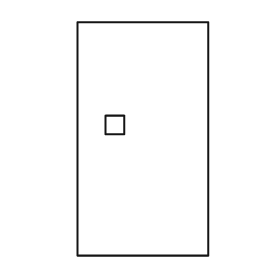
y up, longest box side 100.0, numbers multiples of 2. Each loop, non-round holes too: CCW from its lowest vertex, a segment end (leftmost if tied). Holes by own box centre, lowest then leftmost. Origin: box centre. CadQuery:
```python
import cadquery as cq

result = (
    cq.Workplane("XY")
    .moveTo(-28.0, -50.0)
    .lineTo(28.0, -50.0)
    .lineTo(28.0, 50.0)
    .lineTo(-28.0, 50.0)
    .close()
    .moveTo(-16.0, 2.0)
    .lineTo(-8.0, 2.0)
    .lineTo(-8.0, 10.0)
    .lineTo(-16.0, 10.0)
    .close()
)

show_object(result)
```